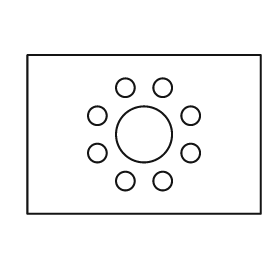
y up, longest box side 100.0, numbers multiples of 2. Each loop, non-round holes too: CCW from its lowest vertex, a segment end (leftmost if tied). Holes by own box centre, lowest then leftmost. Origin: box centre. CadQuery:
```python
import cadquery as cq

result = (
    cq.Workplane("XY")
    .moveTo(-50.0, -34.0)
    .lineTo(50.0, -34.0)
    .lineTo(50.0, 34.0)
    .lineTo(-50.0, 34.0)
    .close()
    .moveTo(-8.0, -20.0)
    .circle(4.0)
    .moveTo(8.0, -20.0)
    .circle(4.0)
    .moveTo(-20.0, -8.0)
    .circle(4.0)
    .moveTo(20.0, -8.0)
    .circle(4.0)
    .moveTo(0.0, 0.0)
    .circle(12.0)
    .moveTo(-20.0, 8.0)
    .circle(4.0)
    .moveTo(20.0, 8.0)
    .circle(4.0)
    .moveTo(-8.0, 20.0)
    .circle(4.0)
    .moveTo(8.0, 20.0)
    .circle(4.0)
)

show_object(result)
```